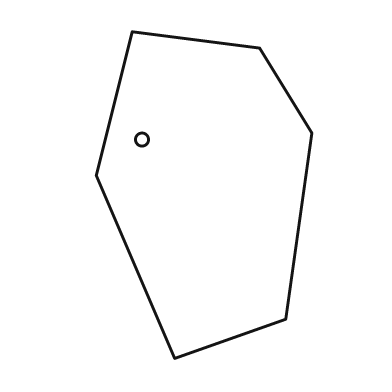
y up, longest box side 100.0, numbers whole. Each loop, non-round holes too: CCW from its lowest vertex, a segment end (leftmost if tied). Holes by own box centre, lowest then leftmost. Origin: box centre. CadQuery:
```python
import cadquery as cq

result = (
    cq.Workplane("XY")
    .moveTo(-9.0, -50.0)
    .lineTo(25.0, -38.0)
    .lineTo(33.0, 19.0)
    .lineTo(17.0, 45.0)
    .lineTo(-22.0, 50.0)
    .lineTo(-33.0, 6.0)
    .close()
    .moveTo(-19.0, 17.0)
    .circle(2.0)
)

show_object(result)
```